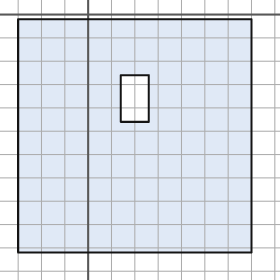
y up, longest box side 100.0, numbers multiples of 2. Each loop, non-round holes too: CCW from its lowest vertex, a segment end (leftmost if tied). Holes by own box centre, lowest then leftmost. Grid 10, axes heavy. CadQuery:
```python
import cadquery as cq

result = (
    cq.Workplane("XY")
    .moveTo(-30.0, -102.0)
    .lineTo(70.0, -102.0)
    .lineTo(70.0, -2.0)
    .lineTo(-30.0, -2.0)
    .close()
    .moveTo(14.0, -46.0)
    .lineTo(26.0, -46.0)
    .lineTo(26.0, -26.0)
    .lineTo(14.0, -26.0)
    .close()
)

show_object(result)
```